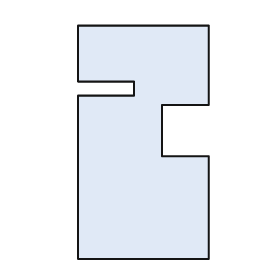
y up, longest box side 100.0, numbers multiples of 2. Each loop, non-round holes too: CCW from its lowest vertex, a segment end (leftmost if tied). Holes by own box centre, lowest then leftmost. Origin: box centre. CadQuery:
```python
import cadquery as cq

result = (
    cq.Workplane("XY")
    .moveTo(-28.0, -50.0)
    .lineTo(28.0, -50.0)
    .lineTo(28.0, -6.0)
    .lineTo(8.0, -6.0)
    .lineTo(8.0, 16.0)
    .lineTo(28.0, 16.0)
    .lineTo(28.0, 50.0)
    .lineTo(-28.0, 50.0)
    .lineTo(-28.0, 26.0)
    .lineTo(-4.0, 26.0)
    .lineTo(-4.0, 20.0)
    .lineTo(-28.0, 20.0)
    .close()
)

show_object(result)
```